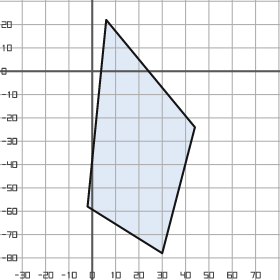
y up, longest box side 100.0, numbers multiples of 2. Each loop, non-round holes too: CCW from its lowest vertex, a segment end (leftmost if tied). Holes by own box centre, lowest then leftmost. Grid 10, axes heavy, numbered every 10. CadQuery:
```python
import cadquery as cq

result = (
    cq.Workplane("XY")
    .moveTo(30.0, -78.0)
    .lineTo(44.0, -24.0)
    .lineTo(6.0, 22.0)
    .lineTo(-2.0, -58.0)
    .close()
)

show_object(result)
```